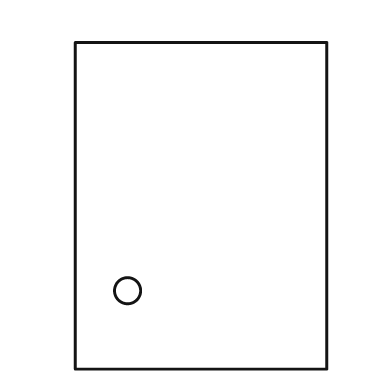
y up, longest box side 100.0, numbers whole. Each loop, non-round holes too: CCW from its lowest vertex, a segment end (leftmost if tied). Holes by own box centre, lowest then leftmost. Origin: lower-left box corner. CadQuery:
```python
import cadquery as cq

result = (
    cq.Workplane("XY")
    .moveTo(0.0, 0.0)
    .lineTo(77.0, 0.0)
    .lineTo(77.0, 100.0)
    .lineTo(0.0, 100.0)
    .close()
    .moveTo(16.0, 24.0)
    .circle(4.0)
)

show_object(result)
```